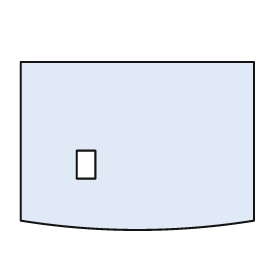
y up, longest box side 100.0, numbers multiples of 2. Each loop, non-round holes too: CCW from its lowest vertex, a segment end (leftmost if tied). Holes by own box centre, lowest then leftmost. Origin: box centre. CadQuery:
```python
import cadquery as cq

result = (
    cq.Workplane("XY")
    .moveTo(-50.0, -32.0)
    .threePointArc((0.0, -36.0), (50.0, -32.0))
    .lineTo(50.0, 36.0)
    .lineTo(-50.0, 36.0)
    .close()
    .moveTo(-26.0, -14.0)
    .lineTo(-18.0, -14.0)
    .lineTo(-18.0, -2.0)
    .lineTo(-26.0, -2.0)
    .close()
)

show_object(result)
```